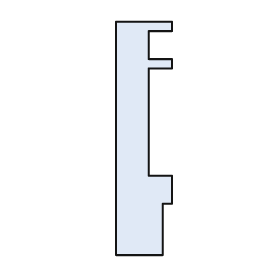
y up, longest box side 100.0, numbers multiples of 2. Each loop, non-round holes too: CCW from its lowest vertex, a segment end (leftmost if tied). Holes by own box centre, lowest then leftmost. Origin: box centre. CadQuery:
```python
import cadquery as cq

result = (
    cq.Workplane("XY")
    .moveTo(-12.0, -50.0)
    .lineTo(8.0, -50.0)
    .lineTo(8.0, -28.0)
    .lineTo(12.0, -28.0)
    .lineTo(12.0, -16.0)
    .lineTo(2.0, -16.0)
    .lineTo(2.0, 30.0)
    .lineTo(12.0, 30.0)
    .lineTo(12.0, 34.0)
    .lineTo(2.0, 34.0)
    .lineTo(2.0, 46.0)
    .lineTo(12.0, 46.0)
    .lineTo(12.0, 50.0)
    .lineTo(-12.0, 50.0)
    .close()
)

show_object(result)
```